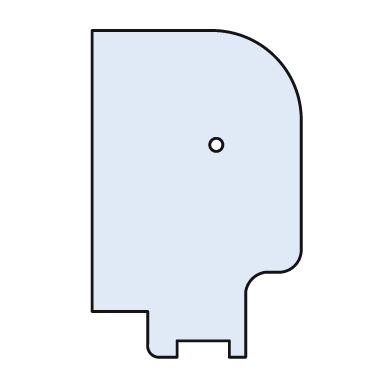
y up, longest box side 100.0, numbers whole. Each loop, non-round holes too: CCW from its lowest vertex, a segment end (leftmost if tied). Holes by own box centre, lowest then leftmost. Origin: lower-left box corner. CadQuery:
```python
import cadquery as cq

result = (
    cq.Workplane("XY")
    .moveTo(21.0, 0.0)
    .lineTo(26.0, 0.0)
    .lineTo(26.0, 5.0)
    .lineTo(42.0, 5.0)
    .lineTo(42.0, 0.0)
    .lineTo(47.0, 0.0)
    .lineTo(47.0, 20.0)
    .threePointArc((49.0, 24.0), (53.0, 26.0))
    .lineTo(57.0, 26.0)
    .threePointArc((62.0, 28.0), (64.0, 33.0))
    .lineTo(64.0, 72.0)
    .threePointArc((56.0, 92.0), (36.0, 100.0))
    .lineTo(0.0, 100.0)
    .lineTo(0.0, 14.0)
    .lineTo(17.0, 14.0)
    .lineTo(17.0, 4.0)
    .threePointArc((18.0, 1.0), (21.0, 0.0))
    .close()
    .moveTo(38.0, 65.0)
    .circle(2.0)
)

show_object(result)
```